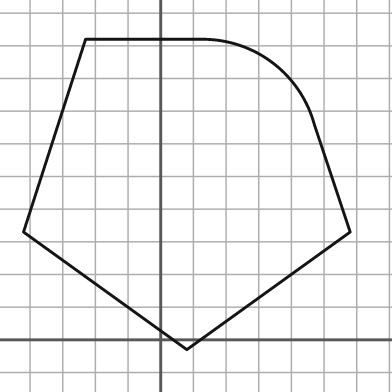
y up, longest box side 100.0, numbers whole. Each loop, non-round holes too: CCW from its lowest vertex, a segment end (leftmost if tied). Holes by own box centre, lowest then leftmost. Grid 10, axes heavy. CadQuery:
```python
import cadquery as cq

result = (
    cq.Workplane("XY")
    .moveTo(8.0, -3.0)
    .lineTo(58.0, 33.0)
    .lineTo(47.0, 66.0)
    .threePointArc((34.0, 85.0), (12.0, 92.0))
    .lineTo(-23.0, 92.0)
    .lineTo(-42.0, 33.0)
    .close()
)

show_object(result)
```